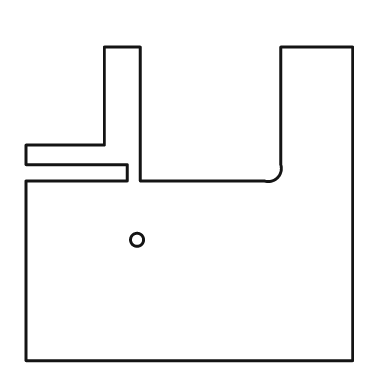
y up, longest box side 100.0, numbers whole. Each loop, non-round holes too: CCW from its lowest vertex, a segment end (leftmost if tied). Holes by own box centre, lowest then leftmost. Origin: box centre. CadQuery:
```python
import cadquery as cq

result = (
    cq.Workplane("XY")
    .moveTo(-50.0, -48.0)
    .lineTo(50.0, -48.0)
    .lineTo(50.0, 48.0)
    .lineTo(28.0, 48.0)
    .lineTo(28.0, 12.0)
    .threePointArc((27.0, 8.0), (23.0, 7.0))
    .lineTo(-15.0, 7.0)
    .lineTo(-15.0, 48.0)
    .lineTo(-26.0, 48.0)
    .lineTo(-26.0, 18.0)
    .lineTo(-50.0, 18.0)
    .lineTo(-50.0, 12.0)
    .lineTo(-19.0, 12.0)
    .lineTo(-19.0, 7.0)
    .lineTo(-50.0, 7.0)
    .close()
    .moveTo(-16.0, -11.0)
    .circle(2.0)
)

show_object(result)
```